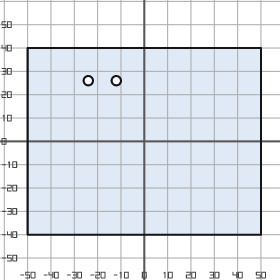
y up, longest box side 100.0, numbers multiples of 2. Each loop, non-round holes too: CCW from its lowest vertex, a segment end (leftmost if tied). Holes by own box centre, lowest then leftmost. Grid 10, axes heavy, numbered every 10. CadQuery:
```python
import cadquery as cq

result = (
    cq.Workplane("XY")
    .moveTo(-50.0, -40.0)
    .lineTo(50.0, -40.0)
    .lineTo(50.0, 40.0)
    .lineTo(-50.0, 40.0)
    .close()
    .moveTo(-24.0, 26.0)
    .circle(2.0)
    .moveTo(-12.0, 26.0)
    .circle(2.0)
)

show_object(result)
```